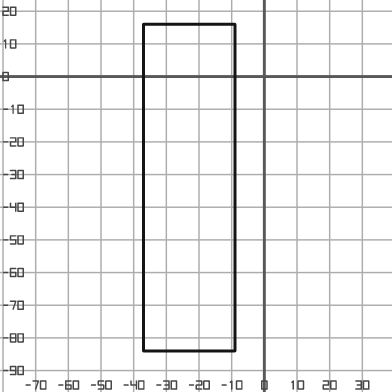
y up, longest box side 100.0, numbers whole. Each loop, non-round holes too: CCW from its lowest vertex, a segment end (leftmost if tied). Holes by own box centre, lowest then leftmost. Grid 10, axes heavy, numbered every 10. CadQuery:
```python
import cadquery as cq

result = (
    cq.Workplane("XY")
    .moveTo(-37.0, -84.0)
    .lineTo(-9.0, -84.0)
    .lineTo(-9.0, 16.0)
    .lineTo(-37.0, 16.0)
    .close()
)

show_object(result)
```